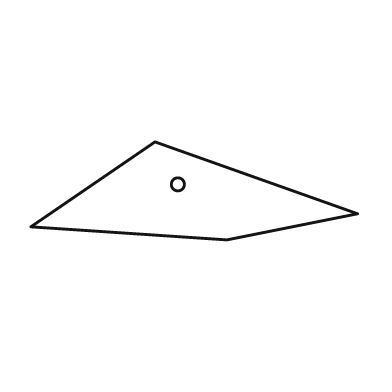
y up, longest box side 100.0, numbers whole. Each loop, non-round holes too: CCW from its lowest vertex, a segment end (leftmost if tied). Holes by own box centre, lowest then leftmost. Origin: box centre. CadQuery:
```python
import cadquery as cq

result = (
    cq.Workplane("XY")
    .moveTo(10.0, -15.0)
    .lineTo(50.0, -7.0)
    .lineTo(-12.0, 15.0)
    .lineTo(-50.0, -11.0)
    .close()
    .moveTo(-5.0, 2.0)
    .circle(2.0)
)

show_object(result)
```